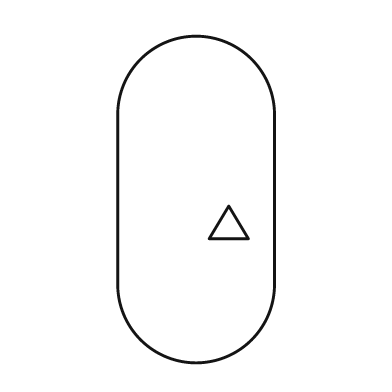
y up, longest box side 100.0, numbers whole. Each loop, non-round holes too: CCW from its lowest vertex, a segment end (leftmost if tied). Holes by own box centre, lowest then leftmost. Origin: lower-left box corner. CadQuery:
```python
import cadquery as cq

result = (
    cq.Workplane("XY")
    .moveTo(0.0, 24.0)
    .threePointArc((24.0, 0.0), (48.0, 24.0))
    .lineTo(48.0, 76.0)
    .threePointArc((24.0, 100.0), (0.0, 76.0))
    .close()
    .moveTo(28.0, 38.0)
    .lineTo(40.0, 38.0)
    .lineTo(34.0, 48.0)
    .close()
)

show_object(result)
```